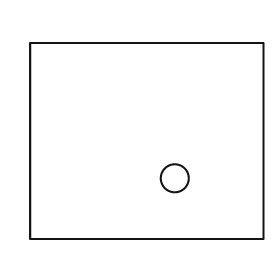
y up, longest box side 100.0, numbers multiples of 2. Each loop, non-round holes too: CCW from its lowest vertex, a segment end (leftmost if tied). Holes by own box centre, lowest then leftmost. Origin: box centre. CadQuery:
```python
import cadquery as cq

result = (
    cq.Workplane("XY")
    .moveTo(-50.0, -42.0)
    .lineTo(50.0, -42.0)
    .lineTo(50.0, 42.0)
    .lineTo(-50.0, 42.0)
    .close()
    .moveTo(12.0, -16.0)
    .circle(6.0)
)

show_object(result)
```